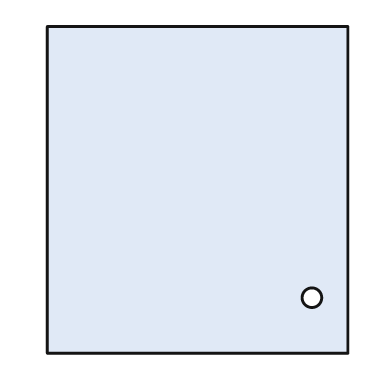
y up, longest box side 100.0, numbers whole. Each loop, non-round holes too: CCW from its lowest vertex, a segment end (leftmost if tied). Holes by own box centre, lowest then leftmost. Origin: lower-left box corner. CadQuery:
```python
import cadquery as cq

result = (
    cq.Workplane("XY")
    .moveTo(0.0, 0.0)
    .lineTo(92.0, 0.0)
    .lineTo(92.0, 100.0)
    .lineTo(0.0, 100.0)
    .close()
    .moveTo(81.0, 17.0)
    .circle(3.0)
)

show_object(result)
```